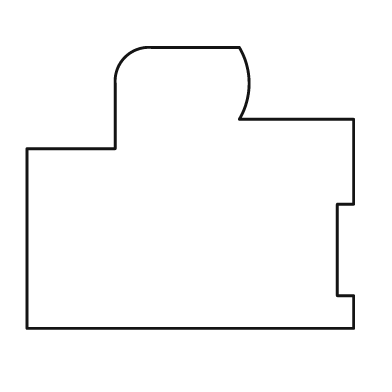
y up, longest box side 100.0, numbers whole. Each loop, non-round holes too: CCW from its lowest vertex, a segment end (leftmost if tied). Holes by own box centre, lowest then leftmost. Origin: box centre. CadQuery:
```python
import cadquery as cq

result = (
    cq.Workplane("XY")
    .moveTo(-50.0, -43.0)
    .lineTo(50.0, -43.0)
    .lineTo(50.0, -33.0)
    .lineTo(45.0, -33.0)
    .lineTo(45.0, -5.0)
    .lineTo(50.0, -5.0)
    .lineTo(50.0, 21.0)
    .lineTo(15.0, 21.0)
    .threePointArc((18.0, 32.0), (15.0, 43.0))
    .lineTo(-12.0, 43.0)
    .threePointArc((-20.0, 40.0), (-23.0, 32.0))
    .lineTo(-23.0, 12.0)
    .lineTo(-50.0, 12.0)
    .close()
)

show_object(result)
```